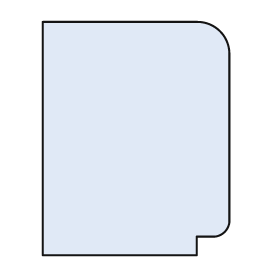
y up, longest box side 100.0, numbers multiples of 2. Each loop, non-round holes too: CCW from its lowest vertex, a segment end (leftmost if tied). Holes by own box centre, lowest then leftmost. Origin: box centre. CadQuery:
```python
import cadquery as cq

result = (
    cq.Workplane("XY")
    .moveTo(-40.0, -50.0)
    .lineTo(26.0, -50.0)
    .lineTo(26.0, -42.0)
    .lineTo(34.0, -42.0)
    .threePointArc((38.0, -40.0), (40.0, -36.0))
    .lineTo(40.0, 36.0)
    .threePointArc((36.0, 46.0), (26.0, 50.0))
    .lineTo(-40.0, 50.0)
    .close()
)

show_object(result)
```